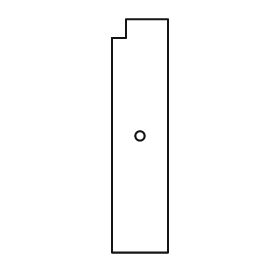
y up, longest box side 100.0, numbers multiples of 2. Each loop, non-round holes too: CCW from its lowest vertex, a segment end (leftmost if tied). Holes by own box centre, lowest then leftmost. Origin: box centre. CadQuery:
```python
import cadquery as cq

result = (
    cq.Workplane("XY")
    .moveTo(-12.0, -50.0)
    .lineTo(12.0, -50.0)
    .lineTo(12.0, 50.0)
    .lineTo(-6.0, 50.0)
    .lineTo(-6.0, 42.0)
    .lineTo(-12.0, 42.0)
    .close()
    .moveTo(0.0, 0.0)
    .circle(2.0)
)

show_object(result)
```